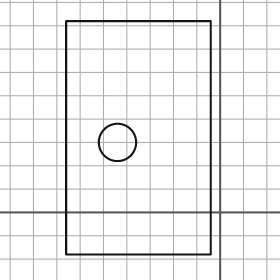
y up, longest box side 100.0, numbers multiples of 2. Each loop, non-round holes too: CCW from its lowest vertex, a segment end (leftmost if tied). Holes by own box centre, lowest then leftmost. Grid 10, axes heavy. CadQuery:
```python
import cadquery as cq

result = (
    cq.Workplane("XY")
    .moveTo(-66.0, -18.0)
    .lineTo(-4.0, -18.0)
    .lineTo(-4.0, 82.0)
    .lineTo(-66.0, 82.0)
    .close()
    .moveTo(-44.0, 30.0)
    .circle(8.0)
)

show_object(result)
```